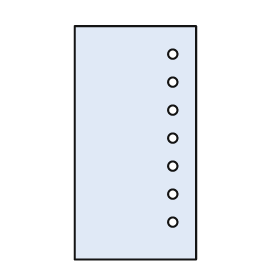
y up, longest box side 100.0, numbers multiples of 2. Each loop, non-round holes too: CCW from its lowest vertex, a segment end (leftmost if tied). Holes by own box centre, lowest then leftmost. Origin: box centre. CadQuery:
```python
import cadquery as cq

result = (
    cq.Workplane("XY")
    .moveTo(-26.0, -50.0)
    .lineTo(26.0, -50.0)
    .lineTo(26.0, 50.0)
    .lineTo(-26.0, 50.0)
    .close()
    .moveTo(16.0, -34.0)
    .circle(2.0)
    .moveTo(16.0, -22.0)
    .circle(2.0)
    .moveTo(16.0, -10.0)
    .circle(2.0)
    .moveTo(16.0, 2.0)
    .circle(2.0)
    .moveTo(16.0, 14.0)
    .circle(2.0)
    .moveTo(16.0, 26.0)
    .circle(2.0)
    .moveTo(16.0, 38.0)
    .circle(2.0)
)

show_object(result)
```